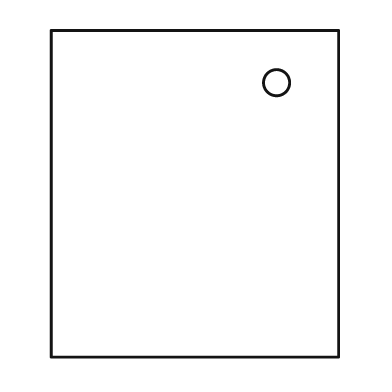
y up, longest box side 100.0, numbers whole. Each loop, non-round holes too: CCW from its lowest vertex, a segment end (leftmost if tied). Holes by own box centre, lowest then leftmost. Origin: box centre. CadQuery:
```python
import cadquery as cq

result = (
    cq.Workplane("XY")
    .moveTo(-44.0, -50.0)
    .lineTo(44.0, -50.0)
    .lineTo(44.0, 50.0)
    .lineTo(-44.0, 50.0)
    .close()
    .moveTo(25.0, 34.0)
    .circle(4.0)
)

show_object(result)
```